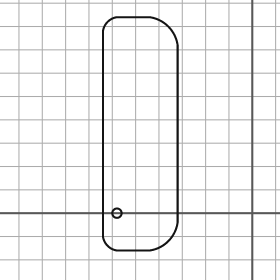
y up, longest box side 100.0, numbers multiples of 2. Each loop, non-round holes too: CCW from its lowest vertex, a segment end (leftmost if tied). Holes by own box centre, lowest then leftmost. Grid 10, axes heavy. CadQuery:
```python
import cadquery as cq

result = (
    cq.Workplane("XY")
    .moveTo(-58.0, -16.0)
    .lineTo(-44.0, -16.0)
    .threePointArc((-36.0, -12.0), (-32.0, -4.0))
    .lineTo(-32.0, 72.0)
    .threePointArc((-36.0, 80.0), (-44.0, 84.0))
    .lineTo(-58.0, 84.0)
    .threePointArc((-62.0, 82.0), (-64.0, 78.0))
    .lineTo(-64.0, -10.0)
    .threePointArc((-62.0, -14.0), (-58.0, -16.0))
    .close()
    .moveTo(-58.0, 0.0)
    .circle(2.0)
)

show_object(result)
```